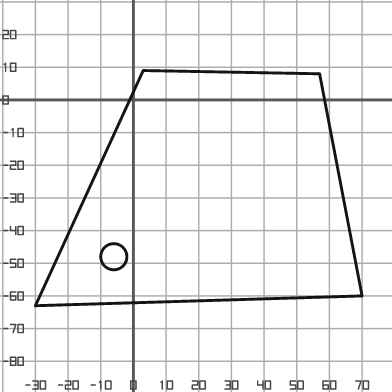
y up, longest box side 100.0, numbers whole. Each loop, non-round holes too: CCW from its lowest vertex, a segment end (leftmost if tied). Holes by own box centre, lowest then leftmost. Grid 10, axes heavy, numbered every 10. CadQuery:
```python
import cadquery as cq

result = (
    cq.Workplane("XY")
    .moveTo(-30.0, -63.0)
    .lineTo(70.0, -60.0)
    .lineTo(57.0, 8.0)
    .lineTo(3.0, 9.0)
    .close()
    .moveTo(-6.0, -48.0)
    .circle(4.0)
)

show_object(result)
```